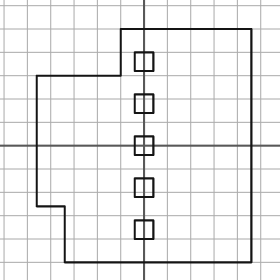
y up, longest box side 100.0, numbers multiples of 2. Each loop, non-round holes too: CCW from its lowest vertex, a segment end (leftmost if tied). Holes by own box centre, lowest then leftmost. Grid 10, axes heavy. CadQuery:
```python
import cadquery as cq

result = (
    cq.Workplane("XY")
    .moveTo(-34.0, -50.0)
    .lineTo(46.0, -50.0)
    .lineTo(46.0, 50.0)
    .lineTo(-10.0, 50.0)
    .lineTo(-10.0, 30.0)
    .lineTo(-46.0, 30.0)
    .lineTo(-46.0, -26.0)
    .lineTo(-34.0, -26.0)
    .close()
    .moveTo(-4.0, -40.0)
    .lineTo(4.0, -40.0)
    .lineTo(4.0, -32.0)
    .lineTo(-4.0, -32.0)
    .close()
    .moveTo(-4.0, -22.0)
    .lineTo(4.0, -22.0)
    .lineTo(4.0, -14.0)
    .lineTo(-4.0, -14.0)
    .close()
    .moveTo(-4.0, -4.0)
    .lineTo(4.0, -4.0)
    .lineTo(4.0, 4.0)
    .lineTo(-4.0, 4.0)
    .close()
    .moveTo(-4.0, 14.0)
    .lineTo(4.0, 14.0)
    .lineTo(4.0, 22.0)
    .lineTo(-4.0, 22.0)
    .close()
    .moveTo(-4.0, 32.0)
    .lineTo(4.0, 32.0)
    .lineTo(4.0, 40.0)
    .lineTo(-4.0, 40.0)
    .close()
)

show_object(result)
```